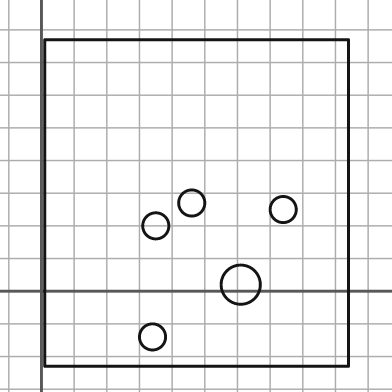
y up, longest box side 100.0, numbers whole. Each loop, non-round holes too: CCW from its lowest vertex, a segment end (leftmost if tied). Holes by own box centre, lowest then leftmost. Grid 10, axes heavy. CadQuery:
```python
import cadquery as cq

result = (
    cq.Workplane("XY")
    .moveTo(1.0, -23.0)
    .lineTo(94.0, -23.0)
    .lineTo(94.0, 77.0)
    .lineTo(1.0, 77.0)
    .close()
    .moveTo(34.0, -14.0)
    .circle(4.0)
    .moveTo(61.0, 2.0)
    .circle(6.0)
    .moveTo(35.0, 20.0)
    .circle(4.0)
    .moveTo(74.0, 25.0)
    .circle(4.0)
    .moveTo(46.0, 27.0)
    .circle(4.0)
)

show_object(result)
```